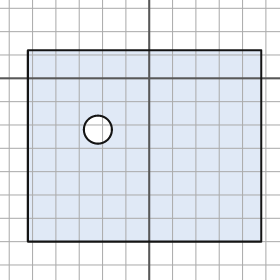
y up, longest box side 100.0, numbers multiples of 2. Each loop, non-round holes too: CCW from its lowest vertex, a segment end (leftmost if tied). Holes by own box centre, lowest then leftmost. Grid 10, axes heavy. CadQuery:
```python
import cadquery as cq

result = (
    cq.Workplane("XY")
    .moveTo(-52.0, -70.0)
    .lineTo(48.0, -70.0)
    .lineTo(48.0, 12.0)
    .lineTo(-52.0, 12.0)
    .close()
    .moveTo(-22.0, -22.0)
    .circle(6.0)
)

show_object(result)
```